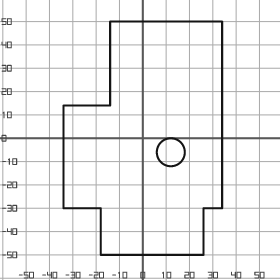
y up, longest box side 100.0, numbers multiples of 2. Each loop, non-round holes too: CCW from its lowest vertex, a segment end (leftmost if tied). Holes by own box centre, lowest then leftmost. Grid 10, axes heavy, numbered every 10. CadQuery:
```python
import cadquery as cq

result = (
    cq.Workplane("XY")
    .moveTo(-18.0, -50.0)
    .lineTo(26.0, -50.0)
    .lineTo(26.0, -30.0)
    .lineTo(34.0, -30.0)
    .lineTo(34.0, 50.0)
    .lineTo(-14.0, 50.0)
    .lineTo(-14.0, 14.0)
    .lineTo(-34.0, 14.0)
    .lineTo(-34.0, -30.0)
    .lineTo(-18.0, -30.0)
    .close()
    .moveTo(12.0, -6.0)
    .circle(6.0)
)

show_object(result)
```